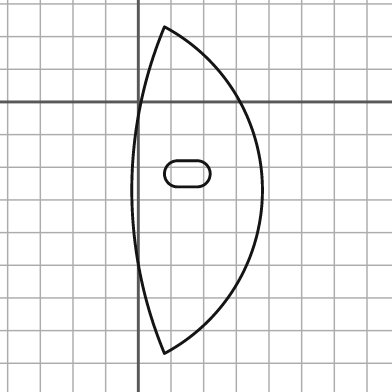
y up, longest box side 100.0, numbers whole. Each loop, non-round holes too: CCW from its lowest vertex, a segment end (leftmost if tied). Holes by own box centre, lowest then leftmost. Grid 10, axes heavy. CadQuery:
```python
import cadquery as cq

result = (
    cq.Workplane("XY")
    .moveTo(8.0, -77.0)
    .threePointArc((38.0, -27.0), (8.0, 23.0))
    .threePointArc((-2.0, -27.0), (8.0, -77.0))
    .close()
    .moveTo(12.0, -26.0)
    .lineTo(18.0, -26.0)
    .threePointArc((22.0, -22.0), (18.0, -18.0))
    .lineTo(12.0, -18.0)
    .threePointArc((8.0, -22.0), (12.0, -26.0))
    .close()
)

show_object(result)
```